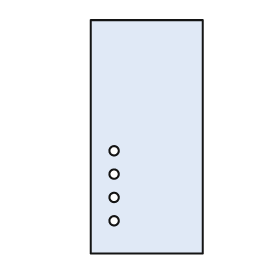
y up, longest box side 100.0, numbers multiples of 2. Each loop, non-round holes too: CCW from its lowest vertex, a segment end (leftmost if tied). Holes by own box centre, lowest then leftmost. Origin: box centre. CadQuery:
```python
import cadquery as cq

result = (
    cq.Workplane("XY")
    .moveTo(-24.0, -50.0)
    .lineTo(24.0, -50.0)
    .lineTo(24.0, 50.0)
    .lineTo(-24.0, 50.0)
    .close()
    .moveTo(-14.0, -36.0)
    .circle(2.0)
    .moveTo(-14.0, -26.0)
    .circle(2.0)
    .moveTo(-14.0, -16.0)
    .circle(2.0)
    .moveTo(-14.0, -6.0)
    .circle(2.0)
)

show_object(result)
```